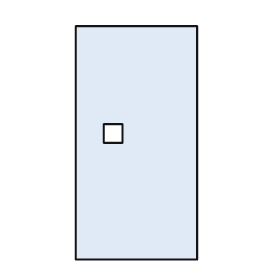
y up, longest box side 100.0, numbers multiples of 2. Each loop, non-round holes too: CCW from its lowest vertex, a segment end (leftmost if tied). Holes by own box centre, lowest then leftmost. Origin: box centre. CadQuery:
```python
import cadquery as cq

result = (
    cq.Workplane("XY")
    .moveTo(-26.0, -50.0)
    .lineTo(26.0, -50.0)
    .lineTo(26.0, 50.0)
    .lineTo(-26.0, 50.0)
    .close()
    .moveTo(-14.0, 0.0)
    .lineTo(-6.0, 0.0)
    .lineTo(-6.0, 8.0)
    .lineTo(-14.0, 8.0)
    .close()
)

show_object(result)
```